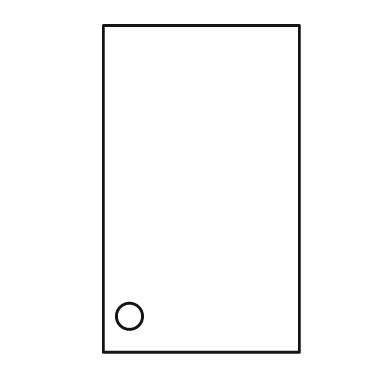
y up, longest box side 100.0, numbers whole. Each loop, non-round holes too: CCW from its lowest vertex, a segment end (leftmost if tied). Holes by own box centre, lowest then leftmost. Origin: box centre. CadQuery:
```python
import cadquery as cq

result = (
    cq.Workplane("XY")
    .moveTo(-30.0, -50.0)
    .lineTo(30.0, -50.0)
    .lineTo(30.0, 50.0)
    .lineTo(-30.0, 50.0)
    .close()
    .moveTo(-22.0, -39.0)
    .circle(4.0)
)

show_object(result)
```